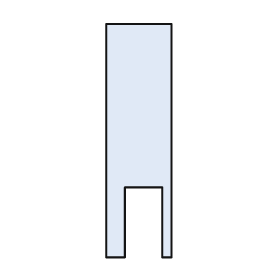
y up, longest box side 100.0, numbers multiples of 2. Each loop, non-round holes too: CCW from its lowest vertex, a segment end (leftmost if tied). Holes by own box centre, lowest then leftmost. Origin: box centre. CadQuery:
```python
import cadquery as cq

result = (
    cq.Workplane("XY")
    .moveTo(-14.0, -50.0)
    .lineTo(-6.0, -50.0)
    .lineTo(-6.0, -20.0)
    .lineTo(10.0, -20.0)
    .lineTo(10.0, -50.0)
    .lineTo(14.0, -50.0)
    .lineTo(14.0, 50.0)
    .lineTo(-14.0, 50.0)
    .close()
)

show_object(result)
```